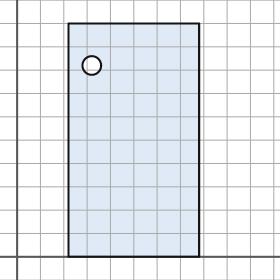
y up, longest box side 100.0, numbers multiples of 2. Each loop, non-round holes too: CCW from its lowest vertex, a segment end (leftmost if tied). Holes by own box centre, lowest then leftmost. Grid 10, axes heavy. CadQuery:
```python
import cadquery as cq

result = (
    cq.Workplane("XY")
    .moveTo(22.0, 0.0)
    .lineTo(78.0, 0.0)
    .lineTo(78.0, 100.0)
    .lineTo(22.0, 100.0)
    .close()
    .moveTo(32.0, 82.0)
    .circle(4.0)
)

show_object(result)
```